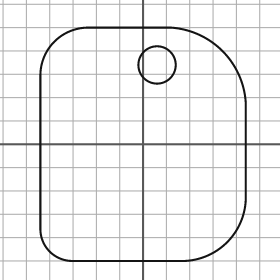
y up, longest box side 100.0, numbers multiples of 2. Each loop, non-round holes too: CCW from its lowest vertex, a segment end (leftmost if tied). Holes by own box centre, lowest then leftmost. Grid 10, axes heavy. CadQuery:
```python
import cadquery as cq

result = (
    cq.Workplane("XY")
    .moveTo(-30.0, -50.0)
    .lineTo(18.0, -50.0)
    .threePointArc((36.0, -42.0), (44.0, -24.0))
    .lineTo(44.0, 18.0)
    .threePointArc((34.0, 40.0), (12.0, 50.0))
    .lineTo(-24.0, 50.0)
    .threePointArc((-38.0, 44.0), (-44.0, 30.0))
    .lineTo(-44.0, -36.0)
    .threePointArc((-40.0, -46.0), (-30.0, -50.0))
    .close()
    .moveTo(6.0, 34.0)
    .circle(8.0)
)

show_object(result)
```